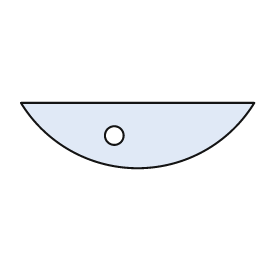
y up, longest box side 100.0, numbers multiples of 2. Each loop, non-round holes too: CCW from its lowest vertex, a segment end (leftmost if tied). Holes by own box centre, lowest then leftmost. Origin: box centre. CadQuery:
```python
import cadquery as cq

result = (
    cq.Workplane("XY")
    .moveTo(-50.0, 14.0)
    .threePointArc((0.0, -14.0), (50.0, 14.0))
    .close()
    .moveTo(-10.0, 0.0)
    .circle(4.0)
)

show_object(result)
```